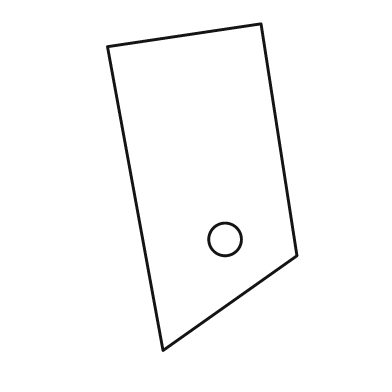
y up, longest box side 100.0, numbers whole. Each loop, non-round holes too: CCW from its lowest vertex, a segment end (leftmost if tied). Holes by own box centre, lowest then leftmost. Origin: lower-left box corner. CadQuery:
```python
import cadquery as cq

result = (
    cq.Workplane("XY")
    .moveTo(17.0, 0.0)
    .lineTo(58.0, 29.0)
    .lineTo(47.0, 100.0)
    .lineTo(0.0, 93.0)
    .close()
    .moveTo(36.0, 34.0)
    .circle(5.0)
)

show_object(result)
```